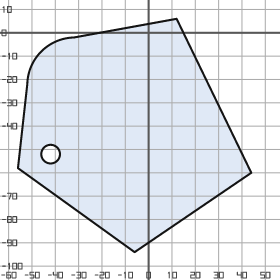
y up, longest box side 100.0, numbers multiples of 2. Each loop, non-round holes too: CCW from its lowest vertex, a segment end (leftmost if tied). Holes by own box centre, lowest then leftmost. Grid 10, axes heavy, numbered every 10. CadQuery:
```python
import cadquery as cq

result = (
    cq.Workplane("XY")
    .moveTo(-6.0, -94.0)
    .lineTo(44.0, -60.0)
    .lineTo(12.0, 6.0)
    .lineTo(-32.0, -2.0)
    .threePointArc((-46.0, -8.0), (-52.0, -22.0))
    .lineTo(-56.0, -58.0)
    .close()
    .moveTo(-42.0, -52.0)
    .circle(4.0)
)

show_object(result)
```